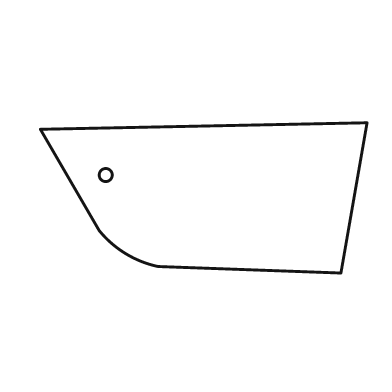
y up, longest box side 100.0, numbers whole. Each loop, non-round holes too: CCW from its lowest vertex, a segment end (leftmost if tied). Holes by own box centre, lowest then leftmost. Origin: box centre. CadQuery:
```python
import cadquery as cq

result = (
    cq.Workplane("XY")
    .moveTo(42.0, -23.0)
    .lineTo(50.0, 23.0)
    .lineTo(-50.0, 21.0)
    .lineTo(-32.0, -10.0)
    .threePointArc((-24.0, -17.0), (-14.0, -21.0))
    .close()
    .moveTo(-30.0, 7.0)
    .circle(2.0)
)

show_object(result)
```